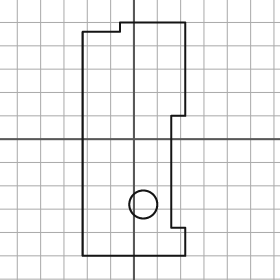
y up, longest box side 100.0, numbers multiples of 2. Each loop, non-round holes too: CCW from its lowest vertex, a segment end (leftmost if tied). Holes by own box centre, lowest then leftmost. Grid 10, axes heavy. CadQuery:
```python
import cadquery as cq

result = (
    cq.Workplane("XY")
    .moveTo(-22.0, -50.0)
    .lineTo(22.0, -50.0)
    .lineTo(22.0, -38.0)
    .lineTo(16.0, -38.0)
    .lineTo(16.0, 10.0)
    .lineTo(22.0, 10.0)
    .lineTo(22.0, 50.0)
    .lineTo(-6.0, 50.0)
    .lineTo(-6.0, 46.0)
    .lineTo(-22.0, 46.0)
    .close()
    .moveTo(4.0, -28.0)
    .circle(6.0)
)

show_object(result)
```